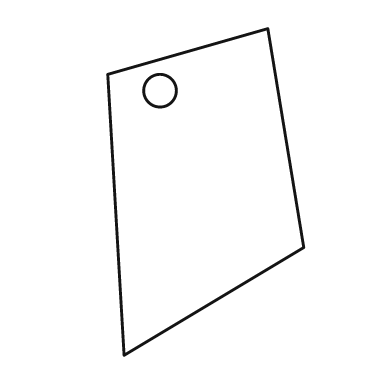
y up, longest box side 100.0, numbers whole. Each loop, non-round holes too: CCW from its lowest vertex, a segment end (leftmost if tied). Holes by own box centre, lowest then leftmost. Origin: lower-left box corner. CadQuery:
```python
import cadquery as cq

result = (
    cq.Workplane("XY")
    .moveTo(5.0, 0.0)
    .lineTo(60.0, 33.0)
    .lineTo(49.0, 100.0)
    .lineTo(0.0, 86.0)
    .close()
    .moveTo(16.0, 81.0)
    .circle(5.0)
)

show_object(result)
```